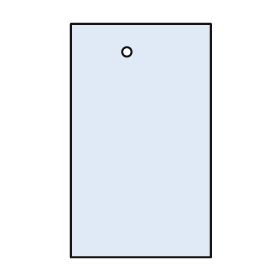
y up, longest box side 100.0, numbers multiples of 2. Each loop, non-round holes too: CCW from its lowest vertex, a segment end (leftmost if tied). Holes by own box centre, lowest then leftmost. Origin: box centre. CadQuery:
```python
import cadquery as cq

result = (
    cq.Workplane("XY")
    .moveTo(-30.0, -50.0)
    .lineTo(30.0, -50.0)
    .lineTo(30.0, 50.0)
    .lineTo(-30.0, 50.0)
    .close()
    .moveTo(-6.0, 38.0)
    .circle(2.0)
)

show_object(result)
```